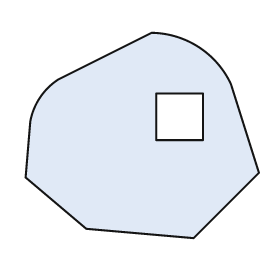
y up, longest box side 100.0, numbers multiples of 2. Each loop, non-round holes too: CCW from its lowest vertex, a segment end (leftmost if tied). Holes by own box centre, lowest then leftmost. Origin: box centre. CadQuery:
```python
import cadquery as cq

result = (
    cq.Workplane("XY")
    .moveTo(22.0, -44.0)
    .lineTo(50.0, -16.0)
    .lineTo(38.0, 22.0)
    .threePointArc((24.0, 38.0), (4.0, 44.0))
    .lineTo(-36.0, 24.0)
    .threePointArc((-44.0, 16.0), (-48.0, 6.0))
    .lineTo(-50.0, -18.0)
    .lineTo(-24.0, -40.0)
    .close()
    .moveTo(6.0, -2.0)
    .lineTo(26.0, -2.0)
    .lineTo(26.0, 18.0)
    .lineTo(6.0, 18.0)
    .close()
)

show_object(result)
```